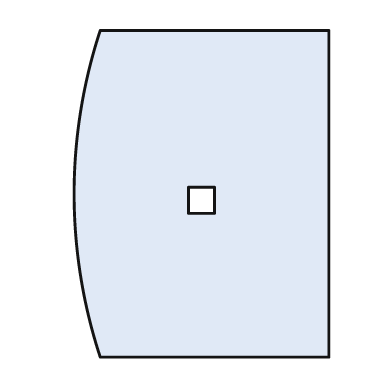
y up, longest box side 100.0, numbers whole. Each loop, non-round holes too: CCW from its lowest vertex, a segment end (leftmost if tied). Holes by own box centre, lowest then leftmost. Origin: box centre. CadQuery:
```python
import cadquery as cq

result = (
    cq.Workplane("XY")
    .moveTo(-31.0, -50.0)
    .lineTo(39.0, -50.0)
    .lineTo(39.0, 50.0)
    .lineTo(-31.0, 50.0)
    .threePointArc((-39.0, 0.0), (-31.0, -50.0))
    .close()
    .moveTo(-4.0, -6.0)
    .lineTo(4.0, -6.0)
    .lineTo(4.0, 2.0)
    .lineTo(-4.0, 2.0)
    .close()
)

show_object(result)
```